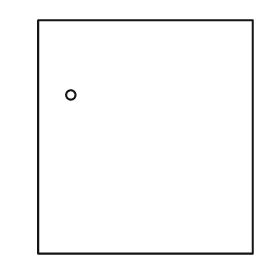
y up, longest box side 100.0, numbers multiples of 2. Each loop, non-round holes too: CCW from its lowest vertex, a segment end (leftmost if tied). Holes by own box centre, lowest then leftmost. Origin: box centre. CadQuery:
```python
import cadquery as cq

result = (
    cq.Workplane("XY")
    .moveTo(-46.0, -50.0)
    .lineTo(46.0, -50.0)
    .lineTo(46.0, 50.0)
    .lineTo(-46.0, 50.0)
    .close()
    .moveTo(-32.0, 18.0)
    .circle(2.0)
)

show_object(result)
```